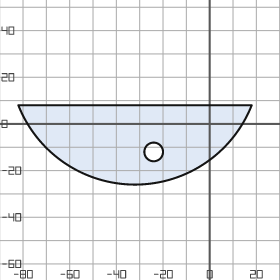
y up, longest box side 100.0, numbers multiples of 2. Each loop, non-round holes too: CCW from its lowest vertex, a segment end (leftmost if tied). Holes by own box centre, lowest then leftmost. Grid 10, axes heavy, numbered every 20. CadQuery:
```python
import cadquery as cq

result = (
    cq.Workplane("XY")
    .moveTo(-82.0, 8.0)
    .threePointArc((-32.0, -26.0), (18.0, 8.0))
    .close()
    .moveTo(-24.0, -12.0)
    .circle(4.0)
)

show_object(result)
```